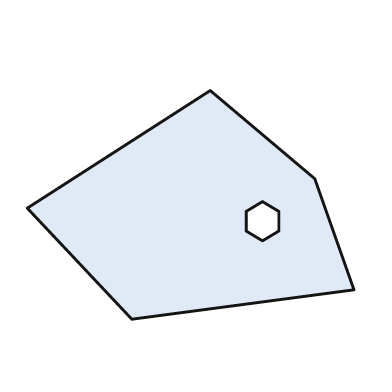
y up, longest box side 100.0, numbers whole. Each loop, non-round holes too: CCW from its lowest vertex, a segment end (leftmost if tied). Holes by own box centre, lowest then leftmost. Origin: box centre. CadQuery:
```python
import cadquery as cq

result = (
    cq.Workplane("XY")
    .moveTo(-18.0, -35.0)
    .lineTo(50.0, -26.0)
    .lineTo(38.0, 8.0)
    .lineTo(6.0, 35.0)
    .lineTo(-50.0, -1.0)
    .close()
    .moveTo(22.0, -11.0)
    .lineTo(27.0, -8.0)
    .lineTo(27.0, -2.0)
    .lineTo(22.0, 1.0)
    .lineTo(17.0, -2.0)
    .lineTo(17.0, -8.0)
    .close()
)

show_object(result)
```